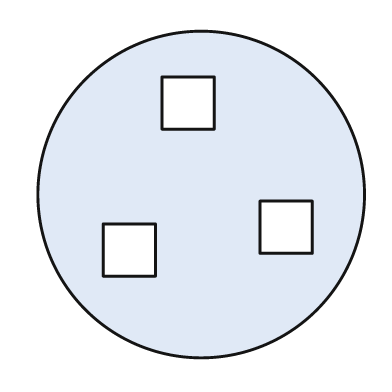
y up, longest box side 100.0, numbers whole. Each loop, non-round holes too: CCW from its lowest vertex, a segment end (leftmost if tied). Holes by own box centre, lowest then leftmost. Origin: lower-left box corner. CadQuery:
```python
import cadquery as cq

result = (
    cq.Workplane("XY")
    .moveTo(50.0, 50.0)
    .circle(50.0)
    .moveTo(20.0, 25.0)
    .lineTo(36.0, 25.0)
    .lineTo(36.0, 41.0)
    .lineTo(20.0, 41.0)
    .close()
    .moveTo(68.0, 32.0)
    .lineTo(84.0, 32.0)
    .lineTo(84.0, 48.0)
    .lineTo(68.0, 48.0)
    .close()
    .moveTo(38.0, 70.0)
    .lineTo(54.0, 70.0)
    .lineTo(54.0, 86.0)
    .lineTo(38.0, 86.0)
    .close()
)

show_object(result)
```